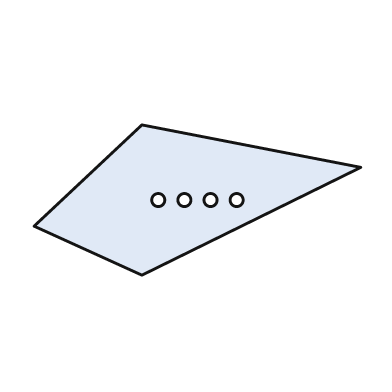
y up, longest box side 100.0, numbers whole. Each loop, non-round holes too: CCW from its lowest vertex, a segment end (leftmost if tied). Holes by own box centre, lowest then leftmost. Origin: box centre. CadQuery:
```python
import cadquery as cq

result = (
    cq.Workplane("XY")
    .moveTo(-17.0, -23.0)
    .lineTo(50.0, 10.0)
    .lineTo(-17.0, 23.0)
    .lineTo(-50.0, -8.0)
    .close()
    .moveTo(-12.0, 0.0)
    .circle(2.0)
    .moveTo(-4.0, 0.0)
    .circle(2.0)
    .moveTo(4.0, 0.0)
    .circle(2.0)
    .moveTo(12.0, 0.0)
    .circle(2.0)
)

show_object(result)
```